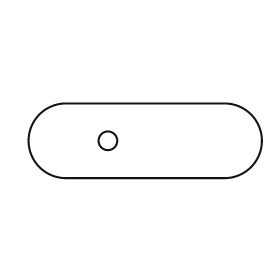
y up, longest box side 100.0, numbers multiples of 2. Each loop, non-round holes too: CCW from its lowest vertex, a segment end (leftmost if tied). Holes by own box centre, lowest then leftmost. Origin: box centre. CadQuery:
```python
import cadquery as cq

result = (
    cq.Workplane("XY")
    .moveTo(-34.0, -16.0)
    .lineTo(34.0, -16.0)
    .threePointArc((50.0, 0.0), (34.0, 16.0))
    .lineTo(-34.0, 16.0)
    .threePointArc((-50.0, 0.0), (-34.0, -16.0))
    .close()
    .moveTo(-16.0, 0.0)
    .circle(4.0)
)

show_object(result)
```